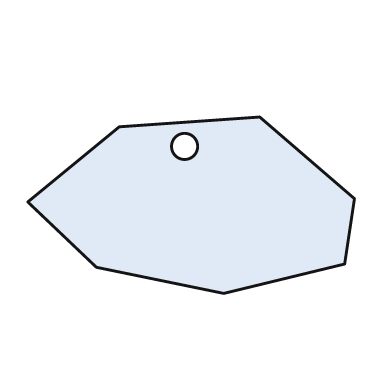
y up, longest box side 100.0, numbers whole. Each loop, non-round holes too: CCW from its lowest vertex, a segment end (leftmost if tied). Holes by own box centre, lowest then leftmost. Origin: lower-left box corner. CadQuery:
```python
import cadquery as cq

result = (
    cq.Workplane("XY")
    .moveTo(60.0, 0.0)
    .lineTo(97.0, 9.0)
    .lineTo(100.0, 29.0)
    .lineTo(71.0, 54.0)
    .lineTo(28.0, 51.0)
    .lineTo(0.0, 28.0)
    .lineTo(21.0, 8.0)
    .close()
    .moveTo(48.0, 45.0)
    .circle(4.0)
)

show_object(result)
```